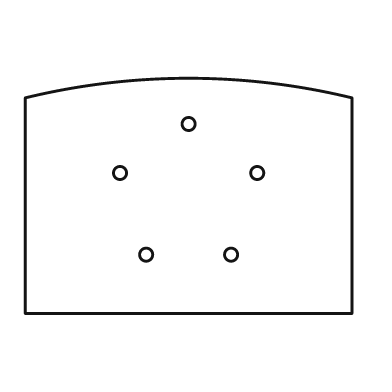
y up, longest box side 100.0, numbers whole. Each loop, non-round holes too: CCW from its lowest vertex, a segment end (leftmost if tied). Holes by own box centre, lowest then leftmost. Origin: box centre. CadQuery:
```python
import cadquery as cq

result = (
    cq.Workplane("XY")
    .moveTo(-50.0, -36.0)
    .lineTo(50.0, -36.0)
    .lineTo(50.0, 30.0)
    .threePointArc((0.0, 36.0), (-50.0, 30.0))
    .close()
    .moveTo(-13.0, -18.0)
    .circle(2.0)
    .moveTo(13.0, -18.0)
    .circle(2.0)
    .moveTo(-21.0, 7.0)
    .circle(2.0)
    .moveTo(21.0, 7.0)
    .circle(2.0)
    .moveTo(0.0, 22.0)
    .circle(2.0)
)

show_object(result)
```